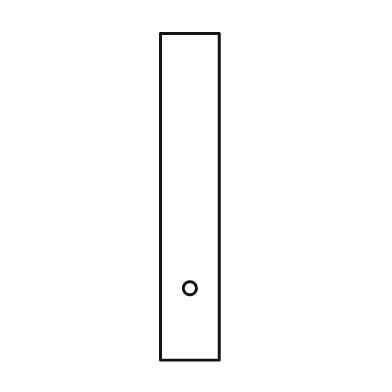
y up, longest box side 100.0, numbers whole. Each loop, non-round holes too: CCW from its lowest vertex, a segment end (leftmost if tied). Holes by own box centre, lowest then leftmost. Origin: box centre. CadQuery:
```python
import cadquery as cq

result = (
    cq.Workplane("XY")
    .moveTo(-9.0, -50.0)
    .lineTo(9.0, -50.0)
    .lineTo(9.0, 50.0)
    .lineTo(-9.0, 50.0)
    .close()
    .moveTo(0.0, -28.0)
    .circle(2.0)
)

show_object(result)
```